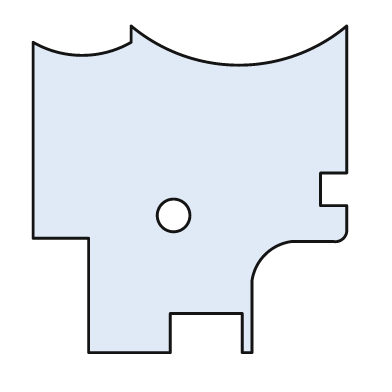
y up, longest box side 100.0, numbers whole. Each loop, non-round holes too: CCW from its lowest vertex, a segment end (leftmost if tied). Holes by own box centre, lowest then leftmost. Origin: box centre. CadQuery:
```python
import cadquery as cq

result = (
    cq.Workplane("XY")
    .moveTo(-31.0, -50.0)
    .lineTo(-6.0, -50.0)
    .lineTo(-6.0, -38.0)
    .lineTo(16.0, -38.0)
    .lineTo(16.0, -50.0)
    .lineTo(19.0, -50.0)
    .lineTo(19.0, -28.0)
    .threePointArc((23.0, -20.0), (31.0, -16.0))
    .lineTo(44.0, -16.0)
    .threePointArc((47.0, -15.0), (48.0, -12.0))
    .lineTo(48.0, -5.0)
    .lineTo(40.0, -5.0)
    .lineTo(40.0, 5.0)
    .lineTo(48.0, 5.0)
    .lineTo(48.0, 50.0)
    .threePointArc((15.0, 38.0), (-18.0, 50.0))
    .lineTo(-18.0, 45.0)
    .threePointArc((-33.0, 41.0), (-48.0, 45.0))
    .lineTo(-48.0, -15.0)
    .lineTo(-31.0, -15.0)
    .close()
    .moveTo(-5.0, -8.0)
    .circle(5.0)
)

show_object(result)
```